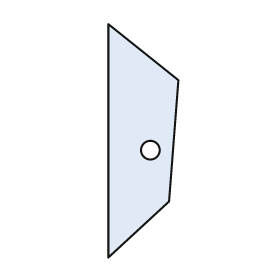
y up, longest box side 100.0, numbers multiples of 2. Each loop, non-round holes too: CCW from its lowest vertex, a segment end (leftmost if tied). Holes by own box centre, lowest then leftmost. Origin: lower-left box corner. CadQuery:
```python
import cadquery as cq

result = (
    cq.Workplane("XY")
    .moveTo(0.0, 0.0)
    .lineTo(26.0, 24.0)
    .lineTo(30.0, 76.0)
    .lineTo(0.0, 100.0)
    .close()
    .moveTo(18.0, 46.0)
    .circle(4.0)
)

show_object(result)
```